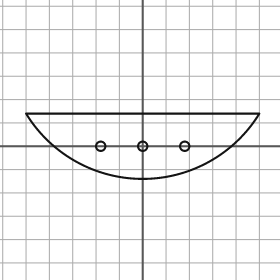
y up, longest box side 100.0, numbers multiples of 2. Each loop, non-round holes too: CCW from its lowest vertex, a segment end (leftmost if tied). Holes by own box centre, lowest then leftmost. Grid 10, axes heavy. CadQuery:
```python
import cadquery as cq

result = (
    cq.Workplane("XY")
    .moveTo(-50.0, 14.0)
    .threePointArc((0.0, -14.0), (50.0, 14.0))
    .close()
    .moveTo(-18.0, 0.0)
    .circle(2.0)
    .moveTo(0.0, 0.0)
    .circle(2.0)
    .moveTo(18.0, 0.0)
    .circle(2.0)
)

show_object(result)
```